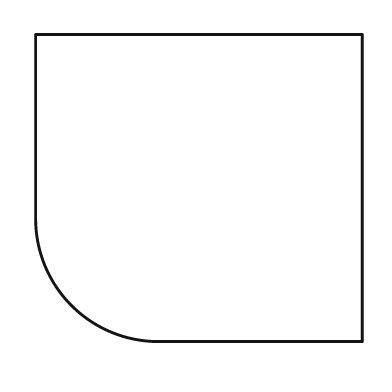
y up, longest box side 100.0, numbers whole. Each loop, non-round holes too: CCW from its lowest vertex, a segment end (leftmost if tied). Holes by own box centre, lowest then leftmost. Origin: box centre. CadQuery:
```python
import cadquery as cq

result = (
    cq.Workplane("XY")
    .moveTo(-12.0, -47.0)
    .lineTo(50.0, -47.0)
    .lineTo(50.0, 47.0)
    .lineTo(-50.0, 47.0)
    .lineTo(-50.0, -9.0)
    .threePointArc((-39.0, -36.0), (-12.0, -47.0))
    .close()
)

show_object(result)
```